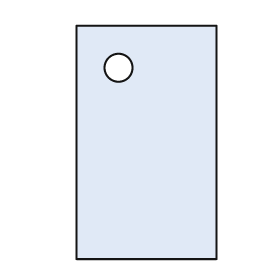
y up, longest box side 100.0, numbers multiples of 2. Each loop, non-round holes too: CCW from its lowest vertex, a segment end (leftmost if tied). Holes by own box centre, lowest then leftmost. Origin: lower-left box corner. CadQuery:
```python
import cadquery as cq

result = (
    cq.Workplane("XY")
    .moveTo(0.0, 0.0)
    .lineTo(60.0, 0.0)
    .lineTo(60.0, 100.0)
    .lineTo(0.0, 100.0)
    .close()
    .moveTo(18.0, 82.0)
    .circle(6.0)
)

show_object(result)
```